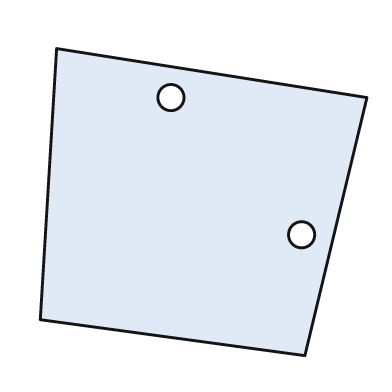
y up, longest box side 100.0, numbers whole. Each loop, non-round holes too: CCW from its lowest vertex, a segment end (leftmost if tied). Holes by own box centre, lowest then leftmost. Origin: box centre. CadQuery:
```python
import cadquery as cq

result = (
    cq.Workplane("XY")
    .moveTo(31.0, -47.0)
    .lineTo(50.0, 32.0)
    .lineTo(-45.0, 47.0)
    .lineTo(-50.0, -36.0)
    .close()
    .moveTo(30.0, -10.0)
    .circle(4.0)
    .moveTo(-10.0, 32.0)
    .circle(4.0)
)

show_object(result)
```